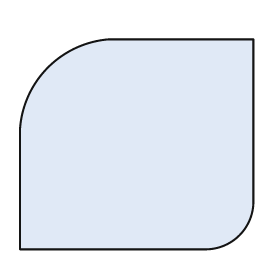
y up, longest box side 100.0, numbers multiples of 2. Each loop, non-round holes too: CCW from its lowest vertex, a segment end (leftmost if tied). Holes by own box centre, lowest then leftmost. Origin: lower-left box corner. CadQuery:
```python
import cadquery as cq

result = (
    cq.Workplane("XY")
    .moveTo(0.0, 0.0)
    .lineTo(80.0, 0.0)
    .threePointArc((94.0, 6.0), (100.0, 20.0))
    .lineTo(100.0, 90.0)
    .lineTo(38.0, 90.0)
    .threePointArc((12.0, 78.0), (0.0, 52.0))
    .close()
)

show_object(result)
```